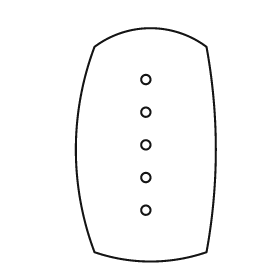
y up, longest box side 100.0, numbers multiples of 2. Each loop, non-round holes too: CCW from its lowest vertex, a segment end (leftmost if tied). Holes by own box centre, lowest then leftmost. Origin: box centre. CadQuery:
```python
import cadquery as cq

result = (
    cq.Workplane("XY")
    .moveTo(-22.0, -46.0)
    .threePointArc((2.0, -50.0), (26.0, -46.0))
    .threePointArc((30.0, -2.0), (26.0, 42.0))
    .threePointArc((2.0, 50.0), (-22.0, 42.0))
    .threePointArc((-30.0, -2.0), (-22.0, -46.0))
    .close()
    .moveTo(0.0, -28.0)
    .circle(2.0)
    .moveTo(0.0, -14.0)
    .circle(2.0)
    .moveTo(0.0, 0.0)
    .circle(2.0)
    .moveTo(0.0, 14.0)
    .circle(2.0)
    .moveTo(0.0, 28.0)
    .circle(2.0)
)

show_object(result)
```